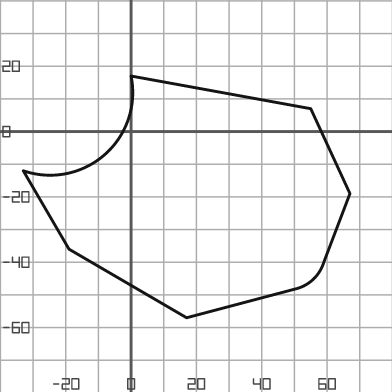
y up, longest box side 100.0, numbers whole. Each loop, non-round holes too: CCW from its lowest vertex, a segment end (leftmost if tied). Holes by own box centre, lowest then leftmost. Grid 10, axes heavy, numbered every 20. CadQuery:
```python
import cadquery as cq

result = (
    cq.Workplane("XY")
    .moveTo(17.0, -57.0)
    .lineTo(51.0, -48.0)
    .threePointArc((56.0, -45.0), (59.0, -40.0))
    .lineTo(67.0, -19.0)
    .lineTo(55.0, 7.0)
    .lineTo(0.0, 17.0)
    .threePointArc((-8.0, -7.0), (-33.0, -12.0))
    .lineTo(-19.0, -36.0)
    .close()
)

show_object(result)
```